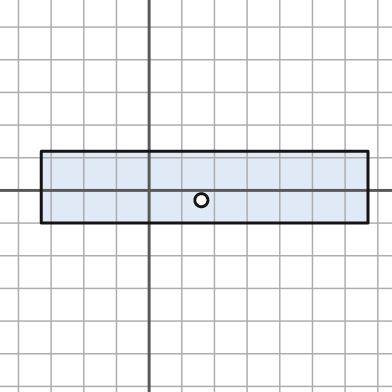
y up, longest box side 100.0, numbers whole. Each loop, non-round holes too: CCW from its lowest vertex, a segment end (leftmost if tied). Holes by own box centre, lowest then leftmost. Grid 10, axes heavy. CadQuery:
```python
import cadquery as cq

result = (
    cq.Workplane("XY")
    .moveTo(-33.0, -10.0)
    .lineTo(67.0, -10.0)
    .lineTo(67.0, 12.0)
    .lineTo(-33.0, 12.0)
    .close()
    .moveTo(16.0, -3.0)
    .circle(2.0)
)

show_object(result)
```